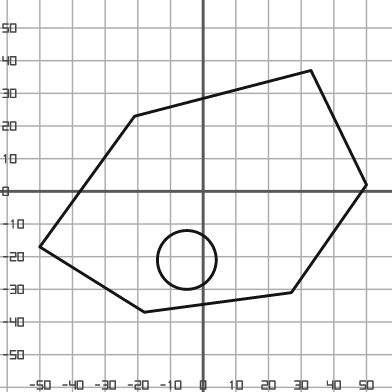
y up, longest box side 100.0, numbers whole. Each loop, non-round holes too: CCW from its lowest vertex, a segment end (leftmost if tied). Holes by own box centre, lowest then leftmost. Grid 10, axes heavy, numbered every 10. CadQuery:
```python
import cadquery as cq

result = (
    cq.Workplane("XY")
    .moveTo(-18.0, -37.0)
    .lineTo(27.0, -31.0)
    .lineTo(50.0, 2.0)
    .lineTo(33.0, 37.0)
    .lineTo(-21.0, 23.0)
    .lineTo(-50.0, -17.0)
    .close()
    .moveTo(-5.0, -21.0)
    .circle(9.0)
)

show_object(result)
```